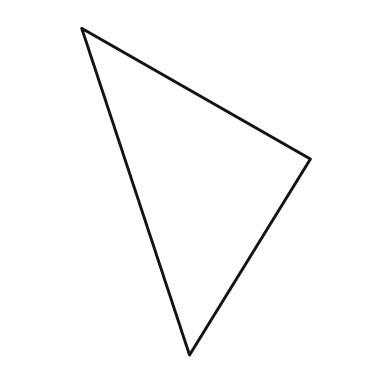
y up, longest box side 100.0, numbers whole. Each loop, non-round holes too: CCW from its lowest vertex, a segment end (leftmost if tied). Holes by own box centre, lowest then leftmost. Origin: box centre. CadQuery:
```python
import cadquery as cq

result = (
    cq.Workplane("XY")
    .moveTo(-2.0, -50.0)
    .lineTo(35.0, 10.0)
    .lineTo(-35.0, 50.0)
    .close()
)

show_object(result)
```